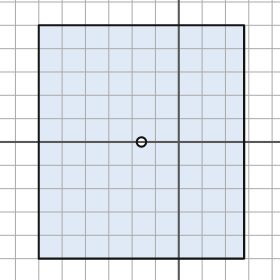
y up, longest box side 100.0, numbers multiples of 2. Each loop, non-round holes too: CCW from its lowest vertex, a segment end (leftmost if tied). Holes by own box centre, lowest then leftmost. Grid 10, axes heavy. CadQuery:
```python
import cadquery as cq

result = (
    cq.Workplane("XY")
    .moveTo(-60.0, -50.0)
    .lineTo(28.0, -50.0)
    .lineTo(28.0, 50.0)
    .lineTo(-60.0, 50.0)
    .close()
    .moveTo(-16.0, 0.0)
    .circle(2.0)
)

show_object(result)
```